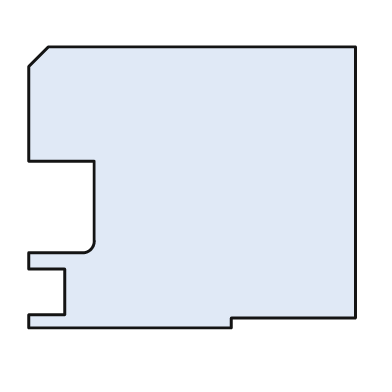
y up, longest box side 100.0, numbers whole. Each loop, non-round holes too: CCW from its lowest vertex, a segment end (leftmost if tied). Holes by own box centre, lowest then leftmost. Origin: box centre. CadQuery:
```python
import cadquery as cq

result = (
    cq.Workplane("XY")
    .moveTo(-50.0, -43.0)
    .lineTo(12.0, -43.0)
    .lineTo(12.0, -40.0)
    .lineTo(50.0, -40.0)
    .lineTo(50.0, 43.0)
    .lineTo(-44.0, 43.0)
    .lineTo(-50.0, 37.0)
    .lineTo(-50.0, 8.0)
    .lineTo(-30.0, 8.0)
    .lineTo(-30.0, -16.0)
    .threePointArc((-31.0, -19.0), (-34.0, -20.0))
    .lineTo(-50.0, -20.0)
    .lineTo(-50.0, -25.0)
    .lineTo(-39.0, -25.0)
    .lineTo(-39.0, -39.0)
    .lineTo(-50.0, -39.0)
    .close()
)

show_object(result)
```